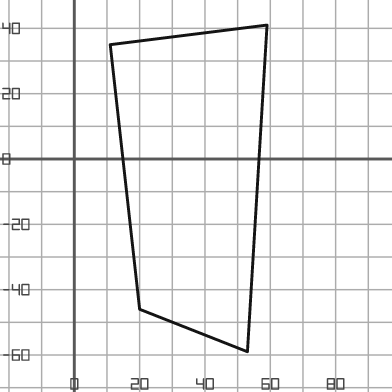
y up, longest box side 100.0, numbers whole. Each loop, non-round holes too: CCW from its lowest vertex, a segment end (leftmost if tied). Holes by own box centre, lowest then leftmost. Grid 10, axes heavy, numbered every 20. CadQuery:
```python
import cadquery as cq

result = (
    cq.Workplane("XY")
    .moveTo(53.0, -59.0)
    .lineTo(59.0, 41.0)
    .lineTo(11.0, 35.0)
    .lineTo(20.0, -46.0)
    .close()
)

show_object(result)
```